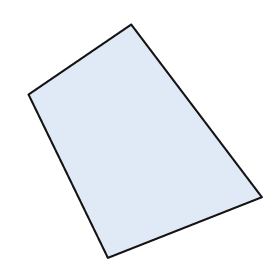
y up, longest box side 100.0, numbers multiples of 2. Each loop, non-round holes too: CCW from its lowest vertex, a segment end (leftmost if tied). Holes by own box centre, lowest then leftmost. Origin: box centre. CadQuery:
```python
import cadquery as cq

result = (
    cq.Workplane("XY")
    .moveTo(-16.0, -50.0)
    .lineTo(50.0, -24.0)
    .lineTo(-6.0, 50.0)
    .lineTo(-50.0, 20.0)
    .close()
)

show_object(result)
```